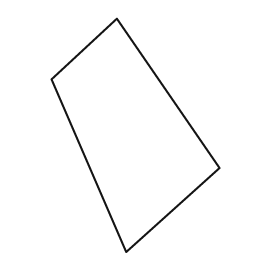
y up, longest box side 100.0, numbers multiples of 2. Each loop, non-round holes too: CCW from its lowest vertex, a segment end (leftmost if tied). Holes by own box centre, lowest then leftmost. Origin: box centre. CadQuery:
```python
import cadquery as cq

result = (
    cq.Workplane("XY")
    .moveTo(-4.0, -50.0)
    .lineTo(36.0, -14.0)
    .lineTo(-8.0, 50.0)
    .lineTo(-36.0, 24.0)
    .close()
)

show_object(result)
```